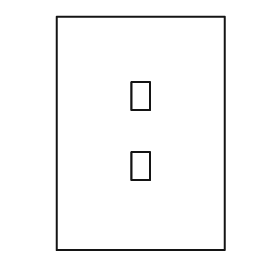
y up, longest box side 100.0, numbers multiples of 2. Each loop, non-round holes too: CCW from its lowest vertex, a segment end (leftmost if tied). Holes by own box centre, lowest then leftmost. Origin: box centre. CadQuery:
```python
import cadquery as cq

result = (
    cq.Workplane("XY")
    .moveTo(-36.0, -50.0)
    .lineTo(36.0, -50.0)
    .lineTo(36.0, 50.0)
    .lineTo(-36.0, 50.0)
    .close()
    .moveTo(-4.0, -20.0)
    .lineTo(4.0, -20.0)
    .lineTo(4.0, -8.0)
    .lineTo(-4.0, -8.0)
    .close()
    .moveTo(-4.0, 10.0)
    .lineTo(4.0, 10.0)
    .lineTo(4.0, 22.0)
    .lineTo(-4.0, 22.0)
    .close()
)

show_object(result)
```